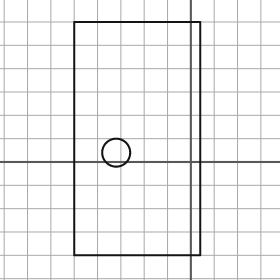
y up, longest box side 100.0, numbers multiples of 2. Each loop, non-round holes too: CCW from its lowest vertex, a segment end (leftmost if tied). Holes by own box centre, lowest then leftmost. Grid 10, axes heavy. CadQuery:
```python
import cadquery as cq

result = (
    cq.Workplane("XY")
    .moveTo(-50.0, -40.0)
    .lineTo(4.0, -40.0)
    .lineTo(4.0, 60.0)
    .lineTo(-50.0, 60.0)
    .close()
    .moveTo(-32.0, 4.0)
    .circle(6.0)
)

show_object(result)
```